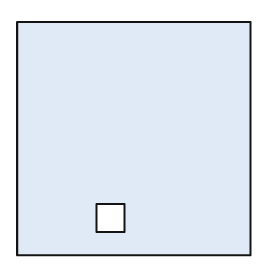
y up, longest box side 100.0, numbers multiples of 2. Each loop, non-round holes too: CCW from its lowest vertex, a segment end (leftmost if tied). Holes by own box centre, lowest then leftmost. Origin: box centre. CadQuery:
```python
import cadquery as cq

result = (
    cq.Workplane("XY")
    .moveTo(-50.0, -50.0)
    .lineTo(50.0, -50.0)
    .lineTo(50.0, 50.0)
    .lineTo(-50.0, 50.0)
    .close()
    .moveTo(-16.0, -40.0)
    .lineTo(-4.0, -40.0)
    .lineTo(-4.0, -28.0)
    .lineTo(-16.0, -28.0)
    .close()
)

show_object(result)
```